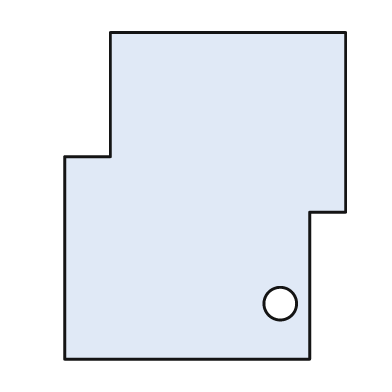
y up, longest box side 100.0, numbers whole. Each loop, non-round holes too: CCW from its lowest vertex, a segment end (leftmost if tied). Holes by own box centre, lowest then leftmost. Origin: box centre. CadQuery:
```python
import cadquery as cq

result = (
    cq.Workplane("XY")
    .moveTo(-43.0, -50.0)
    .lineTo(32.0, -50.0)
    .lineTo(32.0, -5.0)
    .lineTo(43.0, -5.0)
    .lineTo(43.0, 50.0)
    .lineTo(-29.0, 50.0)
    .lineTo(-29.0, 12.0)
    .lineTo(-43.0, 12.0)
    .close()
    .moveTo(23.0, -33.0)
    .circle(5.0)
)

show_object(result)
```